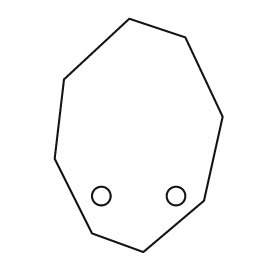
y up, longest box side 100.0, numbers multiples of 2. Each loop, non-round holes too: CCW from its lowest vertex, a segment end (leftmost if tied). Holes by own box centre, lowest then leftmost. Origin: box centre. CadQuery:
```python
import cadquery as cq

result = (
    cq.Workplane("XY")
    .moveTo(2.0, -50.0)
    .lineTo(28.0, -28.0)
    .lineTo(36.0, 8.0)
    .lineTo(20.0, 42.0)
    .lineTo(-4.0, 50.0)
    .lineTo(-32.0, 24.0)
    .lineTo(-36.0, -10.0)
    .lineTo(-20.0, -42.0)
    .close()
    .moveTo(-16.0, -26.0)
    .circle(4.0)
    .moveTo(16.0, -26.0)
    .circle(4.0)
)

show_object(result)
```